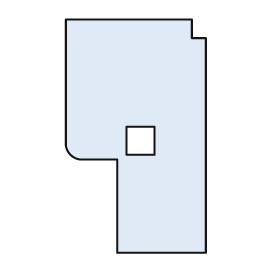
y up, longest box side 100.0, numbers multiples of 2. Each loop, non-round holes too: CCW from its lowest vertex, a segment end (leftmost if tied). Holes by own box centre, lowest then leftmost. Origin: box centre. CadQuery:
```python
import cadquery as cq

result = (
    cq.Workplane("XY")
    .moveTo(-8.0, -50.0)
    .lineTo(30.0, -50.0)
    .lineTo(30.0, 42.0)
    .lineTo(24.0, 42.0)
    .lineTo(24.0, 50.0)
    .lineTo(-30.0, 50.0)
    .lineTo(-30.0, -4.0)
    .threePointArc((-28.0, -8.0), (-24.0, -10.0))
    .lineTo(-8.0, -10.0)
    .close()
    .moveTo(-4.0, -8.0)
    .lineTo(8.0, -8.0)
    .lineTo(8.0, 4.0)
    .lineTo(-4.0, 4.0)
    .close()
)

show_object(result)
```